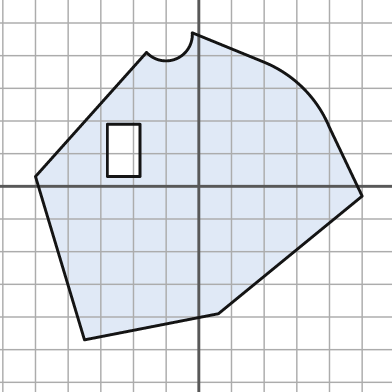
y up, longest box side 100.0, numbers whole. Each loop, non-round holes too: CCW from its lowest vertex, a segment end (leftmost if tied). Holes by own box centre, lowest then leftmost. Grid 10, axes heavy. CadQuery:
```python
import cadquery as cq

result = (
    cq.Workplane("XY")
    .moveTo(-35.0, -47.0)
    .lineTo(6.0, -39.0)
    .lineTo(50.0, -3.0)
    .lineTo(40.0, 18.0)
    .threePointArc((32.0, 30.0), (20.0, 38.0))
    .lineTo(-2.0, 47.0)
    .threePointArc((-7.0, 39.0), (-16.0, 41.0))
    .lineTo(-50.0, 3.0)
    .close()
    .moveTo(-28.0, 3.0)
    .lineTo(-18.0, 3.0)
    .lineTo(-18.0, 19.0)
    .lineTo(-28.0, 19.0)
    .close()
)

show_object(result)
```